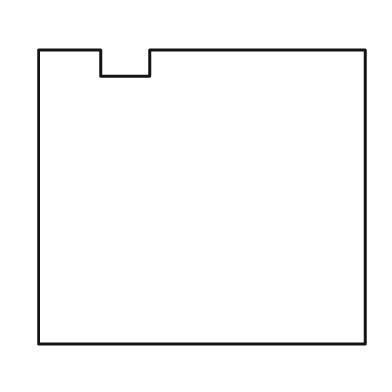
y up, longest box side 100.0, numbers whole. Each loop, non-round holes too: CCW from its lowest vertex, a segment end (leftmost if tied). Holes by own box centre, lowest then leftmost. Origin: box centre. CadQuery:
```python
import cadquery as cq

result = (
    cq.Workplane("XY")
    .moveTo(-50.0, -45.0)
    .lineTo(50.0, -45.0)
    .lineTo(50.0, 45.0)
    .lineTo(-16.0, 45.0)
    .lineTo(-16.0, 37.0)
    .lineTo(-31.0, 37.0)
    .lineTo(-31.0, 45.0)
    .lineTo(-50.0, 45.0)
    .close()
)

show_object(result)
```